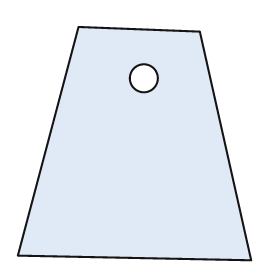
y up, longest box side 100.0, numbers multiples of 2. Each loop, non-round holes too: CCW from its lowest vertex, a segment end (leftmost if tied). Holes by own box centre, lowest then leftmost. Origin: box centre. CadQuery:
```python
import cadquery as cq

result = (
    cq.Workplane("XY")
    .moveTo(50.0, -50.0)
    .lineTo(28.0, 48.0)
    .lineTo(-24.0, 50.0)
    .lineTo(-50.0, -48.0)
    .close()
    .moveTo(4.0, 28.0)
    .circle(6.0)
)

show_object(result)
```